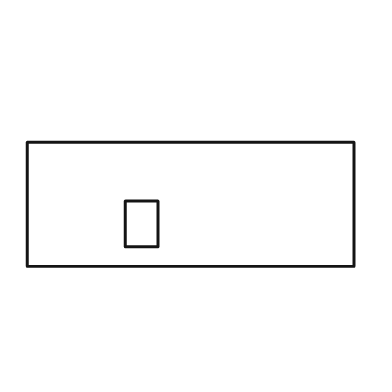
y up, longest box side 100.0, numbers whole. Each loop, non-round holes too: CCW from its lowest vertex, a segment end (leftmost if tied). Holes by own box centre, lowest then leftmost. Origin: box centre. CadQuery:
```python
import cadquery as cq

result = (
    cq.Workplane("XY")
    .moveTo(-50.0, -19.0)
    .lineTo(50.0, -19.0)
    .lineTo(50.0, 19.0)
    .lineTo(-50.0, 19.0)
    .close()
    .moveTo(-20.0, -13.0)
    .lineTo(-10.0, -13.0)
    .lineTo(-10.0, 1.0)
    .lineTo(-20.0, 1.0)
    .close()
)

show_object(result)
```